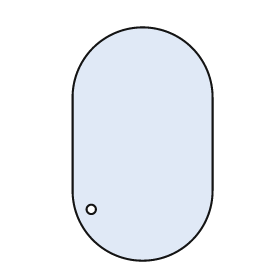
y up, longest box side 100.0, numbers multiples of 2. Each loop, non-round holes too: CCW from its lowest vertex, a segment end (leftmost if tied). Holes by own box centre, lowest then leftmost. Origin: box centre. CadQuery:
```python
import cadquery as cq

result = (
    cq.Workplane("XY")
    .moveTo(-30.0, -20.0)
    .threePointArc((0.0, -50.0), (30.0, -20.0))
    .lineTo(30.0, 20.0)
    .threePointArc((0.0, 50.0), (-30.0, 20.0))
    .close()
    .moveTo(-22.0, -28.0)
    .circle(2.0)
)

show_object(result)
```